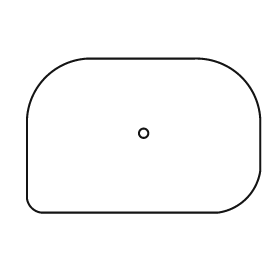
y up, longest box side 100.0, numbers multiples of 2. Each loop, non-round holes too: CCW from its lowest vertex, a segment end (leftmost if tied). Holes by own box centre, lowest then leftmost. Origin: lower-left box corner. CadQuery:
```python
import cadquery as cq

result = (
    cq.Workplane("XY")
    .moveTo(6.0, 0.0)
    .lineTo(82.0, 0.0)
    .threePointArc((94.0, 6.0), (100.0, 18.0))
    .lineTo(100.0, 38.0)
    .threePointArc((92.0, 58.0), (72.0, 66.0))
    .lineTo(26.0, 66.0)
    .threePointArc((8.0, 58.0), (0.0, 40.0))
    .lineTo(0.0, 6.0)
    .threePointArc((2.0, 2.0), (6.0, 0.0))
    .close()
    .moveTo(50.0, 34.0)
    .circle(2.0)
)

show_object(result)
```